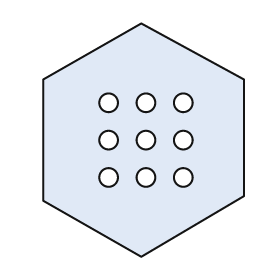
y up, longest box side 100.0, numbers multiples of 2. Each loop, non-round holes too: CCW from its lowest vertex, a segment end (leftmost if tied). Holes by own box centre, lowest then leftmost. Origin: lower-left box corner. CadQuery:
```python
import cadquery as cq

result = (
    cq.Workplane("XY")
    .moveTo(42.0, 0.0)
    .lineTo(86.0, 26.0)
    .lineTo(86.0, 76.0)
    .lineTo(42.0, 100.0)
    .lineTo(0.0, 76.0)
    .lineTo(0.0, 24.0)
    .close()
    .moveTo(28.0, 34.0)
    .circle(4.0)
    .moveTo(44.0, 34.0)
    .circle(4.0)
    .moveTo(60.0, 34.0)
    .circle(4.0)
    .moveTo(28.0, 50.0)
    .circle(4.0)
    .moveTo(44.0, 50.0)
    .circle(4.0)
    .moveTo(60.0, 50.0)
    .circle(4.0)
    .moveTo(28.0, 66.0)
    .circle(4.0)
    .moveTo(44.0, 66.0)
    .circle(4.0)
    .moveTo(60.0, 66.0)
    .circle(4.0)
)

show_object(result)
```